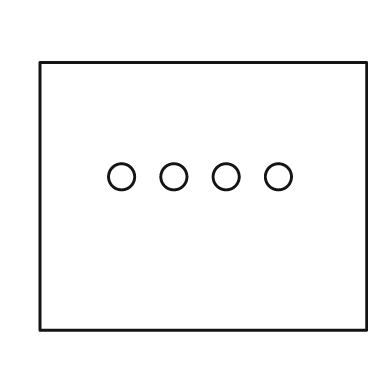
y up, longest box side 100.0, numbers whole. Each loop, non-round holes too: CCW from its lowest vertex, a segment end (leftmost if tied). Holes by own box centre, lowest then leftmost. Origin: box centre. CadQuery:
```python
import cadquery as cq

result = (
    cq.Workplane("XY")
    .moveTo(-50.0, -41.0)
    .lineTo(50.0, -41.0)
    .lineTo(50.0, 41.0)
    .lineTo(-50.0, 41.0)
    .close()
    .moveTo(-25.0, 6.0)
    .circle(4.0)
    .moveTo(-9.0, 6.0)
    .circle(4.0)
    .moveTo(7.0, 6.0)
    .circle(4.0)
    .moveTo(23.0, 6.0)
    .circle(4.0)
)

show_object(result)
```